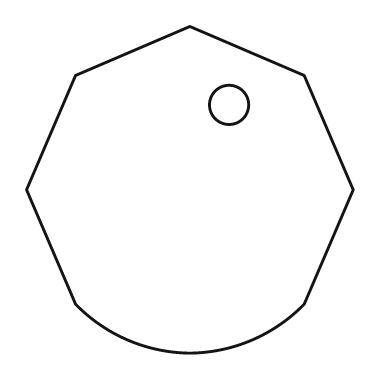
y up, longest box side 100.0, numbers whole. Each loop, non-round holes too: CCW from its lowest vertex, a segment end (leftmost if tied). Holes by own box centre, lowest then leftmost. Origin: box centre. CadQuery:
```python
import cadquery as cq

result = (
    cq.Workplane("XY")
    .moveTo(0.0, -50.0)
    .threePointArc((19.0, -46.0), (35.0, -35.0))
    .lineTo(50.0, 0.0)
    .lineTo(35.0, 35.0)
    .lineTo(0.0, 50.0)
    .lineTo(-35.0, 35.0)
    .lineTo(-50.0, 0.0)
    .lineTo(-35.0, -35.0)
    .threePointArc((-19.0, -46.0), (0.0, -50.0))
    .close()
    .moveTo(12.0, 26.0)
    .circle(6.0)
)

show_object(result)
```